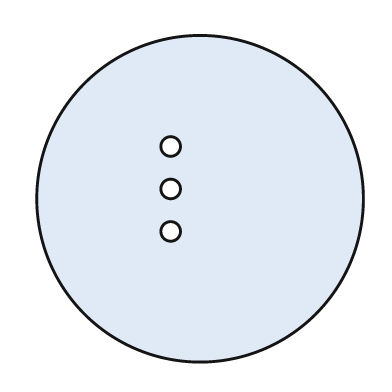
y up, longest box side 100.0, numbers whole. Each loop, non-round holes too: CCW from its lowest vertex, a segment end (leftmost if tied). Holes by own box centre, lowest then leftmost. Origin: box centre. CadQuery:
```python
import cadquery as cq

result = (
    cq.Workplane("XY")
    .moveTo(0.0, 0.0)
    .circle(50.0)
    .moveTo(-9.0, -10.0)
    .circle(3.0)
    .moveTo(-9.0, 3.0)
    .circle(3.0)
    .moveTo(-9.0, 16.0)
    .circle(3.0)
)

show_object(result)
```